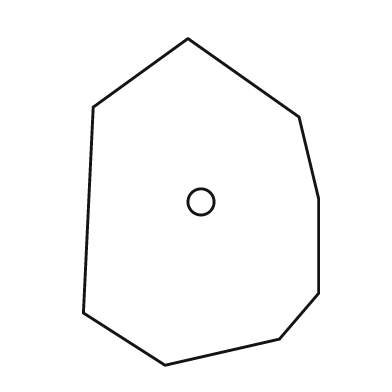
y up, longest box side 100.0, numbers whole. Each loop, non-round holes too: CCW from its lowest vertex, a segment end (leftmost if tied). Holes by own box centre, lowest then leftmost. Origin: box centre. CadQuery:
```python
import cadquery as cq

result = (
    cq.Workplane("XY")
    .moveTo(-11.0, -50.0)
    .lineTo(24.0, -42.0)
    .lineTo(36.0, -28.0)
    .lineTo(36.0, 1.0)
    .lineTo(30.0, 26.0)
    .lineTo(-4.0, 50.0)
    .lineTo(-33.0, 29.0)
    .lineTo(-36.0, -34.0)
    .close()
    .moveTo(0.0, 0.0)
    .circle(4.0)
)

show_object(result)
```